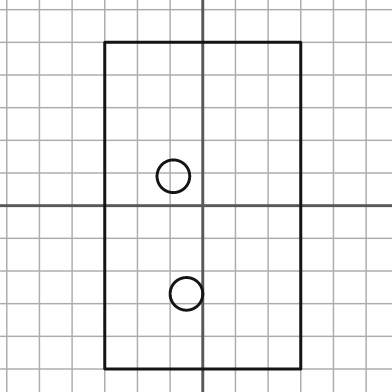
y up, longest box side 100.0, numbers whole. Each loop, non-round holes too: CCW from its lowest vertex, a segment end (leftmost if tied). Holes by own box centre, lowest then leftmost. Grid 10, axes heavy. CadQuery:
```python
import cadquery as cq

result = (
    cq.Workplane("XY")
    .moveTo(-30.0, -50.0)
    .lineTo(30.0, -50.0)
    .lineTo(30.0, 50.0)
    .lineTo(-30.0, 50.0)
    .close()
    .moveTo(-5.0, -27.0)
    .circle(5.0)
    .moveTo(-9.0, 9.0)
    .circle(5.0)
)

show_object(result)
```